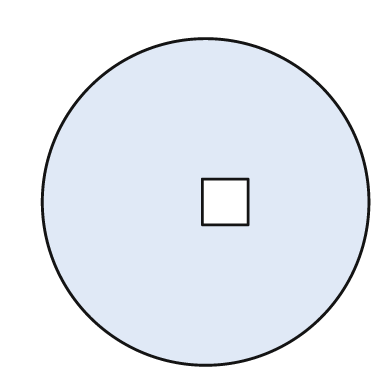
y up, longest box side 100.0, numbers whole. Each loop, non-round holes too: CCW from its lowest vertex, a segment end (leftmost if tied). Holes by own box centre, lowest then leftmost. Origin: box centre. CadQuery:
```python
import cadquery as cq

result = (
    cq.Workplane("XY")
    .moveTo(0.0, 0.0)
    .circle(50.0)
    .moveTo(-1.0, -7.0)
    .lineTo(13.0, -7.0)
    .lineTo(13.0, 7.0)
    .lineTo(-1.0, 7.0)
    .close()
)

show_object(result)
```